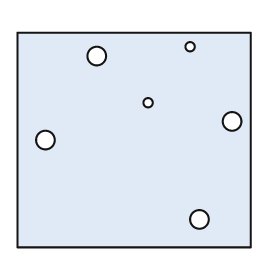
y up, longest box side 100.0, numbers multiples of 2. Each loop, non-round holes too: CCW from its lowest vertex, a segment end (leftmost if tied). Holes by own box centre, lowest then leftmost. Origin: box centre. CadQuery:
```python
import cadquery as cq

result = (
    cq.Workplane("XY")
    .moveTo(-50.0, -46.0)
    .lineTo(50.0, -46.0)
    .lineTo(50.0, 46.0)
    .lineTo(-50.0, 46.0)
    .close()
    .moveTo(28.0, -34.0)
    .circle(4.0)
    .moveTo(-38.0, 0.0)
    .circle(4.0)
    .moveTo(42.0, 8.0)
    .circle(4.0)
    .moveTo(6.0, 16.0)
    .circle(2.0)
    .moveTo(-16.0, 36.0)
    .circle(4.0)
    .moveTo(24.0, 40.0)
    .circle(2.0)
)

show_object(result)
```